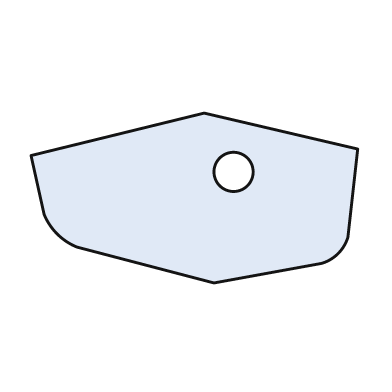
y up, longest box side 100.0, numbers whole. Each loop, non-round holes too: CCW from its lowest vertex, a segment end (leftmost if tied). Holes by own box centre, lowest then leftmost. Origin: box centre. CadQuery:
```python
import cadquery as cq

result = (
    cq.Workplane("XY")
    .moveTo(6.0, -26.0)
    .lineTo(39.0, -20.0)
    .threePointArc((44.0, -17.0), (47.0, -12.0))
    .lineTo(50.0, 15.0)
    .lineTo(3.0, 26.0)
    .lineTo(-50.0, 13.0)
    .lineTo(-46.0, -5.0)
    .threePointArc((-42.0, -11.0), (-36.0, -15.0))
    .close()
    .moveTo(12.0, 8.0)
    .circle(6.0)
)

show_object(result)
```